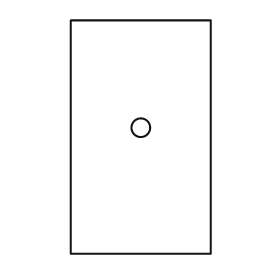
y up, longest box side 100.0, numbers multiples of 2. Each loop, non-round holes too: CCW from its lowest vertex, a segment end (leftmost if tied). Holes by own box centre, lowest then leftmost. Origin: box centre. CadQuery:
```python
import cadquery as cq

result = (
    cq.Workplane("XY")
    .moveTo(-30.0, -50.0)
    .lineTo(30.0, -50.0)
    .lineTo(30.0, 50.0)
    .lineTo(-30.0, 50.0)
    .close()
    .moveTo(0.0, 4.0)
    .circle(4.0)
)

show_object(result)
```